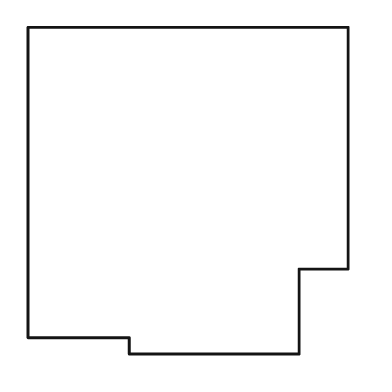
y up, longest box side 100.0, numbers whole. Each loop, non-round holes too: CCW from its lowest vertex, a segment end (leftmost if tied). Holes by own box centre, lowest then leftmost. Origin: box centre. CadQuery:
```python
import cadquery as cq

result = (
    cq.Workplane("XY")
    .moveTo(-18.0, -50.0)
    .lineTo(34.0, -50.0)
    .lineTo(34.0, -24.0)
    .lineTo(49.0, -24.0)
    .lineTo(49.0, 50.0)
    .lineTo(-49.0, 50.0)
    .lineTo(-49.0, -45.0)
    .lineTo(-18.0, -45.0)
    .close()
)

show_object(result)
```